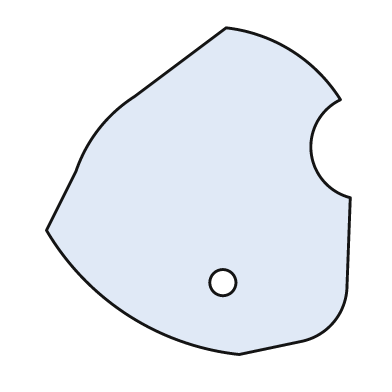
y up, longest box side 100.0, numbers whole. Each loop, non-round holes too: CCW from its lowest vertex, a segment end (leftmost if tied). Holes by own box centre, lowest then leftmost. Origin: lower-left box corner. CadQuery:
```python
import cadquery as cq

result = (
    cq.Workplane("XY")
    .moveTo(59.0, 0.0)
    .lineTo(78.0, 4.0)
    .threePointArc((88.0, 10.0), (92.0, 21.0))
    .lineTo(93.0, 48.0)
    .threePointArc((81.0, 62.0), (90.0, 78.0))
    .threePointArc((75.0, 93.0), (55.0, 100.0))
    .lineTo(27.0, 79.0)
    .threePointArc((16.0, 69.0), (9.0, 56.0))
    .lineTo(0.0, 38.0)
    .threePointArc((25.0, 12.0), (59.0, 0.0))
    .close()
    .moveTo(54.0, 22.0)
    .circle(4.0)
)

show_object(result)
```